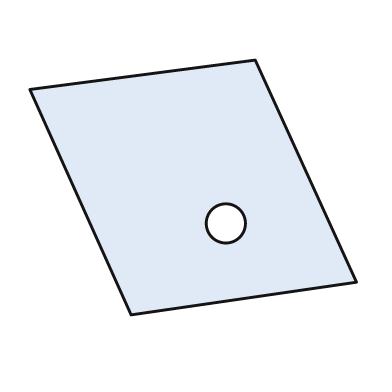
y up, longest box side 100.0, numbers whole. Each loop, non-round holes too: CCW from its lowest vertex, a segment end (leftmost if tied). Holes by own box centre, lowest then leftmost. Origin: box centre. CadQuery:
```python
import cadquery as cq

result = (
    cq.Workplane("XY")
    .moveTo(-19.0, -39.0)
    .lineTo(50.0, -29.0)
    .lineTo(19.0, 39.0)
    .lineTo(-50.0, 30.0)
    .close()
    .moveTo(10.0, -11.0)
    .circle(6.0)
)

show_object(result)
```